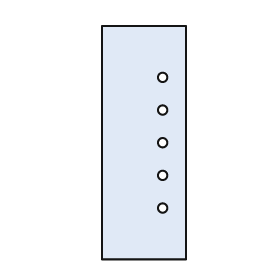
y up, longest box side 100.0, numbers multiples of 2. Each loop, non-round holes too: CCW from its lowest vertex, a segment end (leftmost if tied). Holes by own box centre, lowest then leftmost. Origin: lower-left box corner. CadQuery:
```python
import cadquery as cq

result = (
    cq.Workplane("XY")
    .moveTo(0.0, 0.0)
    .lineTo(36.0, 0.0)
    .lineTo(36.0, 100.0)
    .lineTo(0.0, 100.0)
    .close()
    .moveTo(26.0, 22.0)
    .circle(2.0)
    .moveTo(26.0, 36.0)
    .circle(2.0)
    .moveTo(26.0, 50.0)
    .circle(2.0)
    .moveTo(26.0, 64.0)
    .circle(2.0)
    .moveTo(26.0, 78.0)
    .circle(2.0)
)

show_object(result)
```